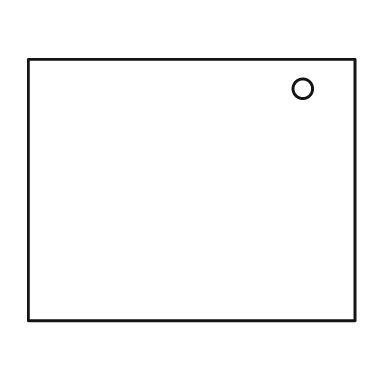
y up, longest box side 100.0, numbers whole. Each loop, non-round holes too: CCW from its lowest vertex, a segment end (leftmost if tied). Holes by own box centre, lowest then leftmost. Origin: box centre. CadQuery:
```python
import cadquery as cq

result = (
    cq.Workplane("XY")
    .moveTo(-50.0, -40.0)
    .lineTo(50.0, -40.0)
    .lineTo(50.0, 40.0)
    .lineTo(-50.0, 40.0)
    .close()
    .moveTo(34.0, 31.0)
    .circle(3.0)
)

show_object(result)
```